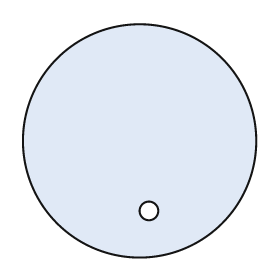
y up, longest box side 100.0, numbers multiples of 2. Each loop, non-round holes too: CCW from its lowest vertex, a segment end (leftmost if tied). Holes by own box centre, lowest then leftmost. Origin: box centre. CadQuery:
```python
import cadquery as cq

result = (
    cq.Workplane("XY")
    .moveTo(0.0, 0.0)
    .circle(50.0)
    .moveTo(4.0, -30.0)
    .circle(4.0)
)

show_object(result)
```